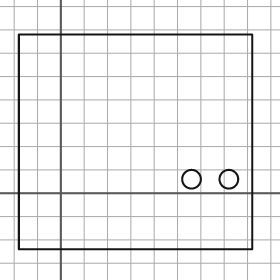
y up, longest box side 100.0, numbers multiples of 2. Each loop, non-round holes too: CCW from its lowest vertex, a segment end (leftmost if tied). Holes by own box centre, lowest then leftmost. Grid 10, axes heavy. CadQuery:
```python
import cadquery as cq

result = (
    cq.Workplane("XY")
    .moveTo(-18.0, -24.0)
    .lineTo(82.0, -24.0)
    .lineTo(82.0, 68.0)
    .lineTo(-18.0, 68.0)
    .close()
    .moveTo(56.0, 6.0)
    .circle(4.0)
    .moveTo(72.0, 6.0)
    .circle(4.0)
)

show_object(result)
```